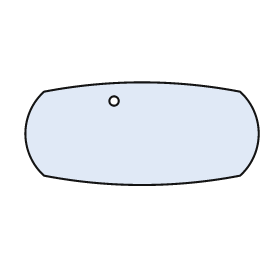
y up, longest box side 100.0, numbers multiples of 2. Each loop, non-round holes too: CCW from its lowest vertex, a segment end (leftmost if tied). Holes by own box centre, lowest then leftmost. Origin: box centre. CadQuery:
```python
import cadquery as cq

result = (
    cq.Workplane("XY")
    .moveTo(-42.0, -18.0)
    .threePointArc((0.0, -22.0), (42.0, -18.0))
    .threePointArc((50.0, 0.0), (42.0, 18.0))
    .threePointArc((0.0, 22.0), (-42.0, 18.0))
    .threePointArc((-50.0, 0.0), (-42.0, -18.0))
    .close()
    .moveTo(-12.0, 14.0)
    .circle(2.0)
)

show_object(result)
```